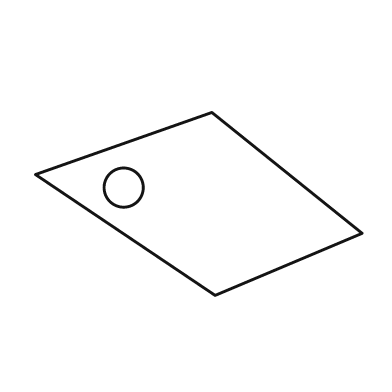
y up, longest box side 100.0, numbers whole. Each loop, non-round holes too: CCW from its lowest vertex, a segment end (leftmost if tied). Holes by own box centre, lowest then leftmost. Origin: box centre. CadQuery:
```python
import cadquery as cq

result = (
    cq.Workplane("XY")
    .moveTo(5.0, -28.0)
    .lineTo(50.0, -9.0)
    .lineTo(4.0, 28.0)
    .lineTo(-50.0, 9.0)
    .close()
    .moveTo(-23.0, 5.0)
    .circle(6.0)
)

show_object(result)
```